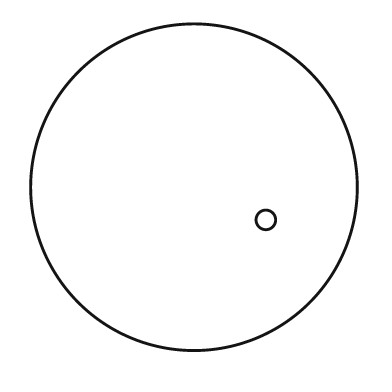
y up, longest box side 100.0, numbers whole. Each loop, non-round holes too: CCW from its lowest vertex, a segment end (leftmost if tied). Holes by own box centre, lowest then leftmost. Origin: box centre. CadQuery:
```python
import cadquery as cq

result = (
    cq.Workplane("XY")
    .moveTo(0.0, 0.0)
    .circle(50.0)
    .moveTo(22.0, -10.0)
    .circle(3.0)
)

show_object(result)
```